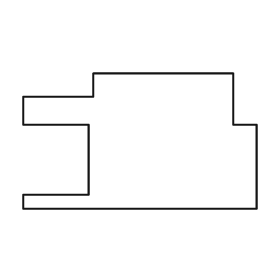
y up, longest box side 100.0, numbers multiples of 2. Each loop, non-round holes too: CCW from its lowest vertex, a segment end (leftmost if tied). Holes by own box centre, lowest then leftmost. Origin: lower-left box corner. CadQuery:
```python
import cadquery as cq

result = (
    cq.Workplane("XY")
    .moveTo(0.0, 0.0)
    .lineTo(100.0, 0.0)
    .lineTo(100.0, 36.0)
    .lineTo(90.0, 36.0)
    .lineTo(90.0, 58.0)
    .lineTo(30.0, 58.0)
    .lineTo(30.0, 48.0)
    .lineTo(0.0, 48.0)
    .lineTo(0.0, 36.0)
    .lineTo(28.0, 36.0)
    .lineTo(28.0, 6.0)
    .lineTo(0.0, 6.0)
    .close()
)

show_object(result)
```